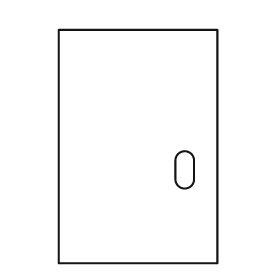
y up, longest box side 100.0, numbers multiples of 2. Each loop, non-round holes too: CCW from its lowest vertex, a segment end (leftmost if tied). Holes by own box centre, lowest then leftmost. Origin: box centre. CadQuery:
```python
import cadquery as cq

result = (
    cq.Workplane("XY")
    .moveTo(-34.0, -50.0)
    .lineTo(34.0, -50.0)
    .lineTo(34.0, 50.0)
    .lineTo(-34.0, 50.0)
    .close()
    .moveTo(16.0, -14.0)
    .threePointArc((20.0, -18.0), (24.0, -14.0))
    .lineTo(24.0, -6.0)
    .threePointArc((20.0, -2.0), (16.0, -6.0))
    .close()
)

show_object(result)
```